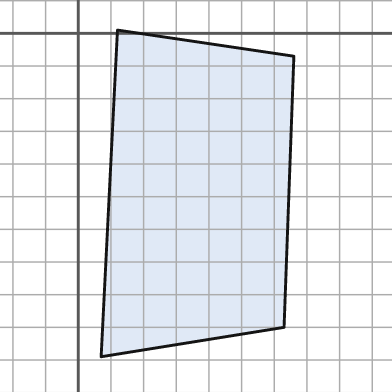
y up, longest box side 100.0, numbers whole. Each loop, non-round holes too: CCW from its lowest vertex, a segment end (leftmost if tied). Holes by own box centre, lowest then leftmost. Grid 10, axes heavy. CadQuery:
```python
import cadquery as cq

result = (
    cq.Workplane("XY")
    .moveTo(7.0, -99.0)
    .lineTo(63.0, -90.0)
    .lineTo(66.0, -7.0)
    .lineTo(12.0, 1.0)
    .close()
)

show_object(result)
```